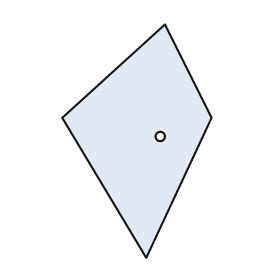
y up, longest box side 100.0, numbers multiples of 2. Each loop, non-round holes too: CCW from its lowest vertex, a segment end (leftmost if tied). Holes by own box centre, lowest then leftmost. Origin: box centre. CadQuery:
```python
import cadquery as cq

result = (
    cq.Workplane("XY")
    .moveTo(4.0, -50.0)
    .lineTo(32.0, 10.0)
    .lineTo(12.0, 50.0)
    .lineTo(-32.0, 10.0)
    .close()
    .moveTo(10.0, 2.0)
    .circle(2.0)
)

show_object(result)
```